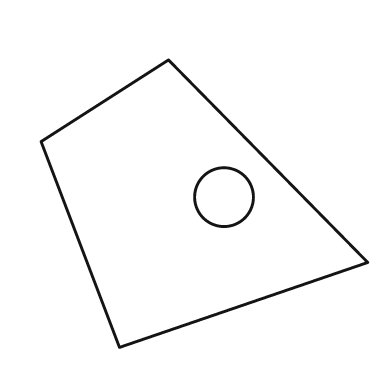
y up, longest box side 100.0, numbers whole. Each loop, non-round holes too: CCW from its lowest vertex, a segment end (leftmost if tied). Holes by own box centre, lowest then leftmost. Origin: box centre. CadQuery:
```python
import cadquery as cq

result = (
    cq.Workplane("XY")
    .moveTo(-26.0, -44.0)
    .lineTo(50.0, -18.0)
    .lineTo(-11.0, 44.0)
    .lineTo(-50.0, 19.0)
    .close()
    .moveTo(6.0, 2.0)
    .circle(9.0)
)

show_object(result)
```